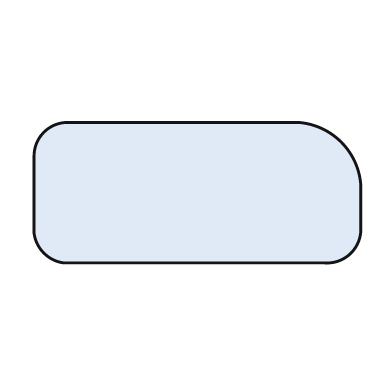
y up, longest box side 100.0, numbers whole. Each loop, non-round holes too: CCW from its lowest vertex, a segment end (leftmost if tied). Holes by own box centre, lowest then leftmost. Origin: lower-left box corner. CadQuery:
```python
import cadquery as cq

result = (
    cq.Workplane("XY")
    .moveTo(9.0, 0.0)
    .lineTo(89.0, 0.0)
    .threePointArc((97.0, 3.0), (100.0, 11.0))
    .lineTo(100.0, 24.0)
    .threePointArc((94.0, 37.0), (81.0, 43.0))
    .lineTo(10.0, 43.0)
    .threePointArc((3.0, 40.0), (0.0, 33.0))
    .lineTo(0.0, 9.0)
    .threePointArc((3.0, 3.0), (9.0, 0.0))
    .close()
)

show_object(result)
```